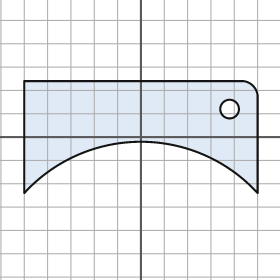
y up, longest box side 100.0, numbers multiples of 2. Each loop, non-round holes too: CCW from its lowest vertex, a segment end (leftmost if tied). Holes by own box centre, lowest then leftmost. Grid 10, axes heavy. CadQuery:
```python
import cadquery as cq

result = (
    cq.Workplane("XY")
    .moveTo(-50.0, -24.0)
    .threePointArc((0.0, -2.0), (50.0, -24.0))
    .lineTo(50.0, 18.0)
    .threePointArc((48.0, 22.0), (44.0, 24.0))
    .lineTo(-50.0, 24.0)
    .close()
    .moveTo(38.0, 12.0)
    .circle(4.0)
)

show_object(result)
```